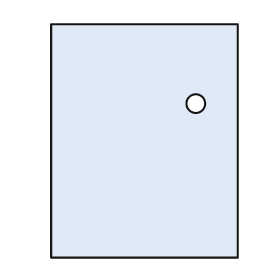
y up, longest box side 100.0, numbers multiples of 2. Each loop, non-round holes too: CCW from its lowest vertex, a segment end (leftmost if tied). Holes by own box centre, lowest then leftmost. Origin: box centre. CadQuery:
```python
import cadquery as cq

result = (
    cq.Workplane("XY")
    .moveTo(-40.0, -50.0)
    .lineTo(40.0, -50.0)
    .lineTo(40.0, 50.0)
    .lineTo(-40.0, 50.0)
    .close()
    .moveTo(22.0, 16.0)
    .circle(4.0)
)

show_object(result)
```